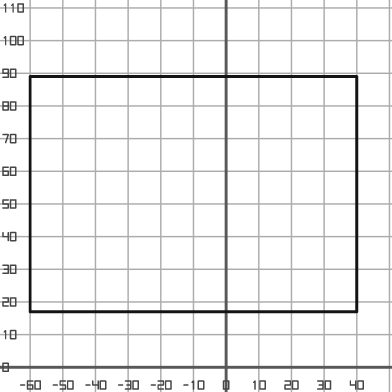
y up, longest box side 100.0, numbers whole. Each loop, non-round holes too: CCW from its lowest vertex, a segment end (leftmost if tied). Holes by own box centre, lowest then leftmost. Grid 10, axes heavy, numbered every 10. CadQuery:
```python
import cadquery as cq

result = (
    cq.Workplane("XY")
    .moveTo(-60.0, 17.0)
    .lineTo(40.0, 17.0)
    .lineTo(40.0, 89.0)
    .lineTo(-60.0, 89.0)
    .close()
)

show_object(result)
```